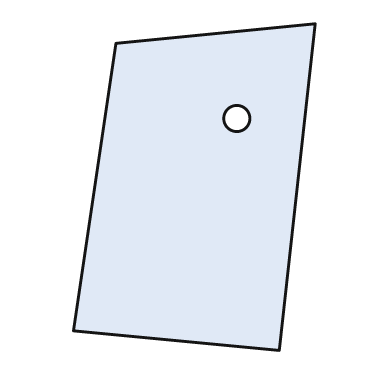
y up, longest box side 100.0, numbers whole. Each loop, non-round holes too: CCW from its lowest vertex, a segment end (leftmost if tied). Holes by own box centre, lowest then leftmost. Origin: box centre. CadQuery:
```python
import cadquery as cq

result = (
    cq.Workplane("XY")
    .moveTo(26.0, -50.0)
    .lineTo(37.0, 50.0)
    .lineTo(-24.0, 44.0)
    .lineTo(-37.0, -44.0)
    .close()
    .moveTo(13.0, 21.0)
    .circle(4.0)
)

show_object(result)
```